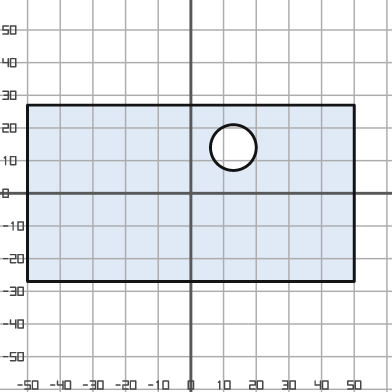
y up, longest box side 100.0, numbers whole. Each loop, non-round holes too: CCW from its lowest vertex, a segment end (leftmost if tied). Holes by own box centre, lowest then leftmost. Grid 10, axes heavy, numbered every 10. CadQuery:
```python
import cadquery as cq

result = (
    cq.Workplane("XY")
    .moveTo(-50.0, -27.0)
    .lineTo(50.0, -27.0)
    .lineTo(50.0, 27.0)
    .lineTo(-50.0, 27.0)
    .close()
    .moveTo(13.0, 14.0)
    .circle(7.0)
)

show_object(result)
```